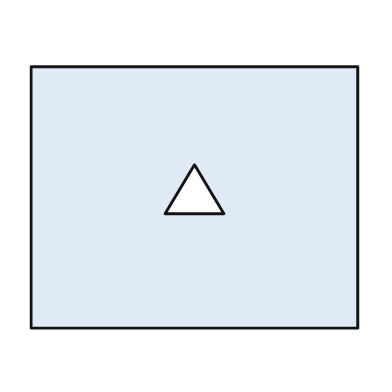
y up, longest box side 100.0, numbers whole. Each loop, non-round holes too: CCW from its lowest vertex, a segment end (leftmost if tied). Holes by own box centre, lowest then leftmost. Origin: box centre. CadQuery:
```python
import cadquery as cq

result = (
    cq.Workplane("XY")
    .moveTo(-50.0, -40.0)
    .lineTo(50.0, -40.0)
    .lineTo(50.0, 40.0)
    .lineTo(-50.0, 40.0)
    .close()
    .moveTo(-9.0, -5.0)
    .lineTo(9.0, -5.0)
    .lineTo(0.0, 10.0)
    .close()
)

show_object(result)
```